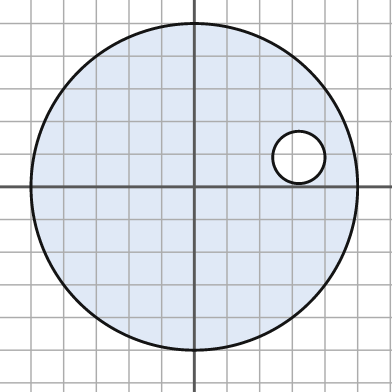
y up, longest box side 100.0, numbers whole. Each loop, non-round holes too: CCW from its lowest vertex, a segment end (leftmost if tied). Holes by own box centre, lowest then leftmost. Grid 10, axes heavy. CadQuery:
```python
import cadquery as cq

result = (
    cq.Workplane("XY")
    .moveTo(0.0, 0.0)
    .circle(50.0)
    .moveTo(32.0, 9.0)
    .circle(8.0)
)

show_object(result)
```